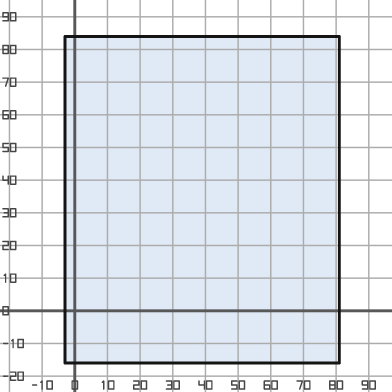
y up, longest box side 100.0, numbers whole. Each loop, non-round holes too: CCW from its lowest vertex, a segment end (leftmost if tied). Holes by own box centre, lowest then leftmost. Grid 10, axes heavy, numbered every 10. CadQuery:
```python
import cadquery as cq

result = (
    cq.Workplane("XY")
    .moveTo(-3.0, -16.0)
    .lineTo(81.0, -16.0)
    .lineTo(81.0, 84.0)
    .lineTo(-3.0, 84.0)
    .close()
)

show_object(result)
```